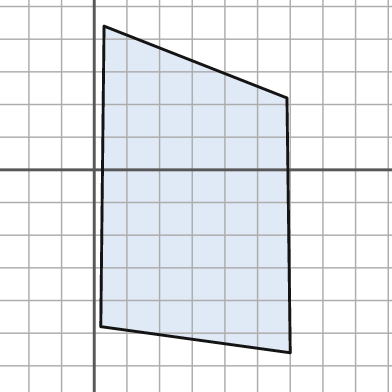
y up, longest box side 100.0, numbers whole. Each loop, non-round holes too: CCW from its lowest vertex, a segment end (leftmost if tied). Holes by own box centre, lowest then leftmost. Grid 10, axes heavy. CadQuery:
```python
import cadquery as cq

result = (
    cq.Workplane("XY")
    .moveTo(60.0, -56.0)
    .lineTo(59.0, 22.0)
    .lineTo(3.0, 44.0)
    .lineTo(2.0, -48.0)
    .close()
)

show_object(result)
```